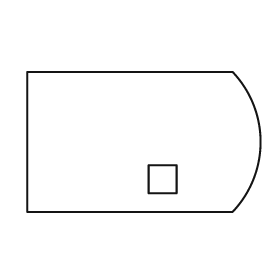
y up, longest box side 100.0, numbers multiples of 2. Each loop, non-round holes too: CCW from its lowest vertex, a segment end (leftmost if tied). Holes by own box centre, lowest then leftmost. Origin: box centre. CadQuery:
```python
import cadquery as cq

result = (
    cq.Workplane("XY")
    .moveTo(-50.0, -30.0)
    .lineTo(38.0, -30.0)
    .threePointArc((50.0, 0.0), (38.0, 30.0))
    .lineTo(-50.0, 30.0)
    .close()
    .moveTo(2.0, -22.0)
    .lineTo(14.0, -22.0)
    .lineTo(14.0, -10.0)
    .lineTo(2.0, -10.0)
    .close()
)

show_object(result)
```